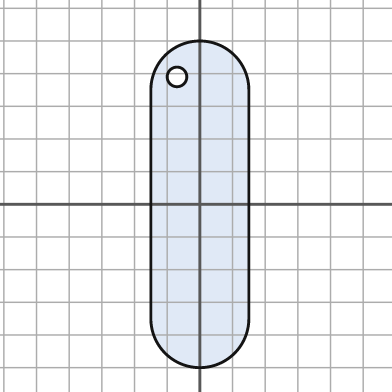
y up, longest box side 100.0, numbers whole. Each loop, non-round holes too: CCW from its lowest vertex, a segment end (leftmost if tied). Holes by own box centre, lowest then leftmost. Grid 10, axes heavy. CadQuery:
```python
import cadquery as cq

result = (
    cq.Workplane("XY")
    .moveTo(-15.0, -35.0)
    .threePointArc((0.0, -50.0), (15.0, -35.0))
    .lineTo(15.0, 35.0)
    .threePointArc((0.0, 50.0), (-15.0, 35.0))
    .close()
    .moveTo(-7.0, 39.0)
    .circle(3.0)
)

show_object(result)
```